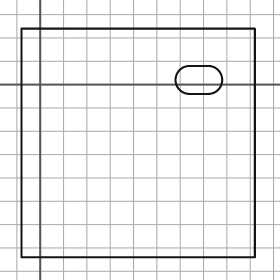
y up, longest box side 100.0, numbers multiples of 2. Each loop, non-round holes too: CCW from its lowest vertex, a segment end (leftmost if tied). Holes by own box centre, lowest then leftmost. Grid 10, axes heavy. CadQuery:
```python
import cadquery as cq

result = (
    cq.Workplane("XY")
    .moveTo(-8.0, -74.0)
    .lineTo(92.0, -74.0)
    .lineTo(92.0, 24.0)
    .lineTo(-8.0, 24.0)
    .close()
    .moveTo(64.0, -4.0)
    .lineTo(72.0, -4.0)
    .threePointArc((78.0, 2.0), (72.0, 8.0))
    .lineTo(64.0, 8.0)
    .threePointArc((58.0, 2.0), (64.0, -4.0))
    .close()
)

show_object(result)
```